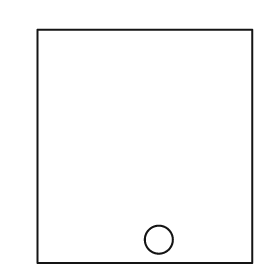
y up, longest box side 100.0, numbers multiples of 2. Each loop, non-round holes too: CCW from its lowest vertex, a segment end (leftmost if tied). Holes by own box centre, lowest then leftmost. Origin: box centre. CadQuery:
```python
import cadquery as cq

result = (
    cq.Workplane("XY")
    .moveTo(-46.0, -50.0)
    .lineTo(46.0, -50.0)
    .lineTo(46.0, 50.0)
    .lineTo(-46.0, 50.0)
    .close()
    .moveTo(6.0, -40.0)
    .circle(6.0)
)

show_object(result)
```